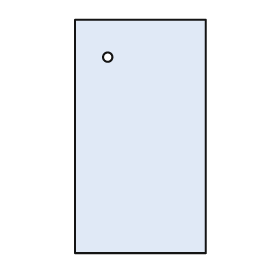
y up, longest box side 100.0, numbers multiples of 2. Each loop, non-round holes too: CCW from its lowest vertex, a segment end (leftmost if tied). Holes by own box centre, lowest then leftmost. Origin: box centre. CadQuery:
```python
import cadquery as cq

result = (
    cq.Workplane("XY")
    .moveTo(-28.0, -50.0)
    .lineTo(28.0, -50.0)
    .lineTo(28.0, 50.0)
    .lineTo(-28.0, 50.0)
    .close()
    .moveTo(-14.0, 34.0)
    .circle(2.0)
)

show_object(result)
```